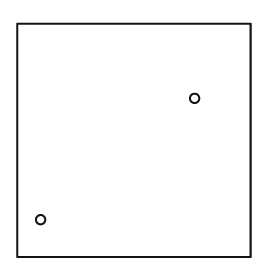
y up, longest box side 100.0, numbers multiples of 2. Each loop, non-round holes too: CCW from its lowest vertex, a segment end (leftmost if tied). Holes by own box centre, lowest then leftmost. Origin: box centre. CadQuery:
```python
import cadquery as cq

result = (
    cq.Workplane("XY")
    .moveTo(-50.0, -50.0)
    .lineTo(50.0, -50.0)
    .lineTo(50.0, 50.0)
    .lineTo(-50.0, 50.0)
    .close()
    .moveTo(-40.0, -34.0)
    .circle(2.0)
    .moveTo(26.0, 18.0)
    .circle(2.0)
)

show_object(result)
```